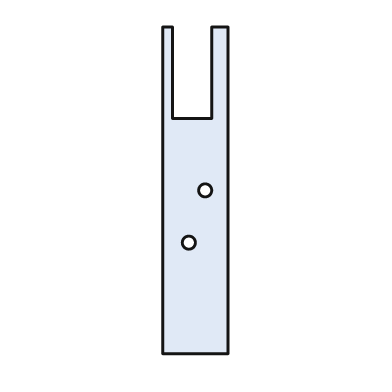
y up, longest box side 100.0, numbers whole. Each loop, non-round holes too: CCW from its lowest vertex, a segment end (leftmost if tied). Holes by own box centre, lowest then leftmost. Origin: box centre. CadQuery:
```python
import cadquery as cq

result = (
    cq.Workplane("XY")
    .moveTo(-10.0, -50.0)
    .lineTo(10.0, -50.0)
    .lineTo(10.0, 50.0)
    .lineTo(5.0, 50.0)
    .lineTo(5.0, 22.0)
    .lineTo(-7.0, 22.0)
    .lineTo(-7.0, 50.0)
    .lineTo(-10.0, 50.0)
    .close()
    .moveTo(-2.0, -16.0)
    .circle(2.0)
    .moveTo(3.0, 0.0)
    .circle(2.0)
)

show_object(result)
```